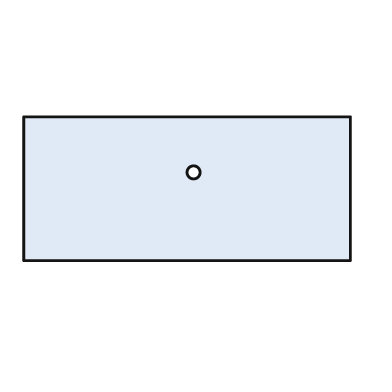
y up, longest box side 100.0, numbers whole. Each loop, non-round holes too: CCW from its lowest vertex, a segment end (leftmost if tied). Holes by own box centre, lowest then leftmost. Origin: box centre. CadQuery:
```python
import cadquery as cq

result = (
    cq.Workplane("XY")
    .moveTo(-50.0, -22.0)
    .lineTo(50.0, -22.0)
    .lineTo(50.0, 22.0)
    .lineTo(-50.0, 22.0)
    .close()
    .moveTo(2.0, 5.0)
    .circle(2.0)
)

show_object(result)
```